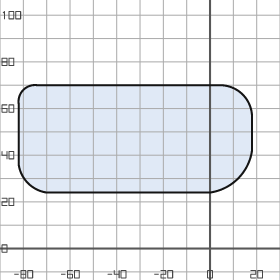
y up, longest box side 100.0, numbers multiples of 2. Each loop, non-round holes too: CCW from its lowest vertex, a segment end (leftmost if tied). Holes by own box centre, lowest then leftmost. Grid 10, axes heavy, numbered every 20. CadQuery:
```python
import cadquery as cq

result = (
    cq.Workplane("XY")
    .moveTo(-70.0, 24.0)
    .lineTo(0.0, 24.0)
    .threePointArc((12.0, 30.0), (18.0, 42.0))
    .lineTo(18.0, 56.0)
    .threePointArc((14.0, 66.0), (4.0, 70.0))
    .lineTo(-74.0, 70.0)
    .threePointArc((-80.0, 68.0), (-82.0, 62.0))
    .lineTo(-82.0, 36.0)
    .threePointArc((-78.0, 28.0), (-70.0, 24.0))
    .close()
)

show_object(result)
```